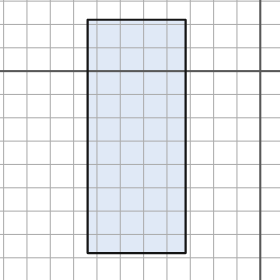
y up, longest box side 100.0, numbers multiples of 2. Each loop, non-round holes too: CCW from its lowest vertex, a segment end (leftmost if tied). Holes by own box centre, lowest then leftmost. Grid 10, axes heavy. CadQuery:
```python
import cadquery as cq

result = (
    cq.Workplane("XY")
    .moveTo(-74.0, -78.0)
    .lineTo(-32.0, -78.0)
    .lineTo(-32.0, 22.0)
    .lineTo(-74.0, 22.0)
    .close()
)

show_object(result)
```